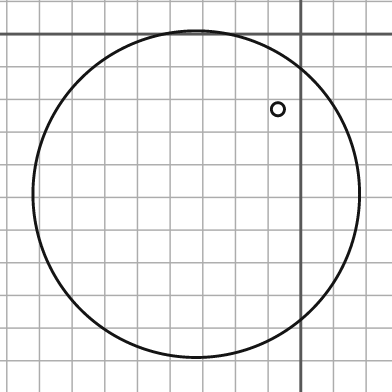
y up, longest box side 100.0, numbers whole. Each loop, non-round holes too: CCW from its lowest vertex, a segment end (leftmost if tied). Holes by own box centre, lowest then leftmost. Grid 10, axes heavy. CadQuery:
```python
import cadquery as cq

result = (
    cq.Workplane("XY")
    .moveTo(-32.0, -49.0)
    .circle(50.0)
    .moveTo(-7.0, -23.0)
    .circle(2.0)
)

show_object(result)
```